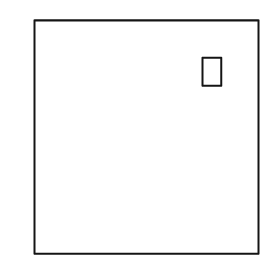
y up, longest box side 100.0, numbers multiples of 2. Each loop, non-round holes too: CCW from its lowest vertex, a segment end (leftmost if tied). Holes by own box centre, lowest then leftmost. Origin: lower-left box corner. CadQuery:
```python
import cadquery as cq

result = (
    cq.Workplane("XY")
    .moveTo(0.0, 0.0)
    .lineTo(96.0, 0.0)
    .lineTo(96.0, 100.0)
    .lineTo(0.0, 100.0)
    .close()
    .moveTo(72.0, 72.0)
    .lineTo(80.0, 72.0)
    .lineTo(80.0, 84.0)
    .lineTo(72.0, 84.0)
    .close()
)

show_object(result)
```